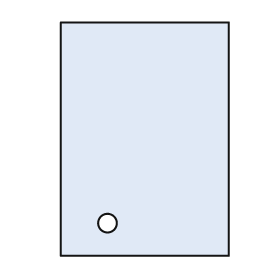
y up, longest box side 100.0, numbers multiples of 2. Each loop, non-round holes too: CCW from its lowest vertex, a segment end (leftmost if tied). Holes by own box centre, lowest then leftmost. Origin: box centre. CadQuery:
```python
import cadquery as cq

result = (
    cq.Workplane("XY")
    .moveTo(-36.0, -50.0)
    .lineTo(36.0, -50.0)
    .lineTo(36.0, 50.0)
    .lineTo(-36.0, 50.0)
    .close()
    .moveTo(-16.0, -36.0)
    .circle(4.0)
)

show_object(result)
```